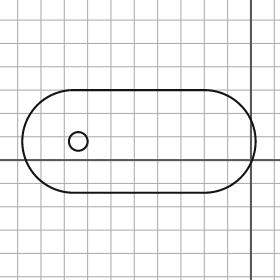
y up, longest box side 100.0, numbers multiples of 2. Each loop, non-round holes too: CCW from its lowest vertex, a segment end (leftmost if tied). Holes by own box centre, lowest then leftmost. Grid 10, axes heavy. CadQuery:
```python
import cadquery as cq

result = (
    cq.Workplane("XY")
    .moveTo(-76.0, -14.0)
    .lineTo(-20.0, -14.0)
    .threePointArc((2.0, 8.0), (-20.0, 30.0))
    .lineTo(-76.0, 30.0)
    .threePointArc((-98.0, 8.0), (-76.0, -14.0))
    .close()
    .moveTo(-74.0, 8.0)
    .circle(4.0)
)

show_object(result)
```